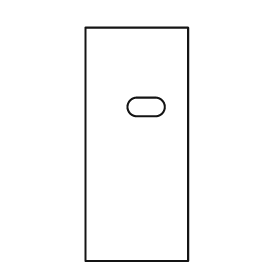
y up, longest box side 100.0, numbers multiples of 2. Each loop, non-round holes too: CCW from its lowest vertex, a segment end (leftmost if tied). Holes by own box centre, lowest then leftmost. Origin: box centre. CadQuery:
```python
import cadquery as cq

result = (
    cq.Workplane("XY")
    .moveTo(-22.0, -50.0)
    .lineTo(22.0, -50.0)
    .lineTo(22.0, 50.0)
    .lineTo(-22.0, 50.0)
    .close()
    .moveTo(0.0, 12.0)
    .lineTo(8.0, 12.0)
    .threePointArc((12.0, 16.0), (8.0, 20.0))
    .lineTo(0.0, 20.0)
    .threePointArc((-4.0, 16.0), (0.0, 12.0))
    .close()
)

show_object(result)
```